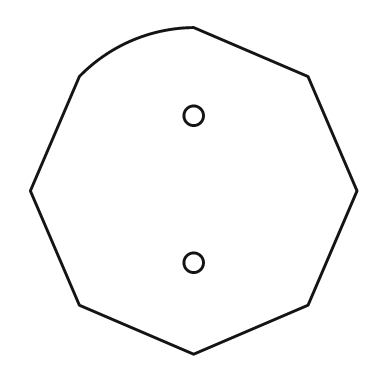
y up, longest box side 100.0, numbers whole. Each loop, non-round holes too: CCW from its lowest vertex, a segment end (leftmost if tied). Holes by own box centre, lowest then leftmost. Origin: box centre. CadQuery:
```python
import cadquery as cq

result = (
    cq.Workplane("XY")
    .moveTo(0.0, -50.0)
    .lineTo(35.0, -35.0)
    .lineTo(50.0, 0.0)
    .lineTo(35.0, 35.0)
    .lineTo(0.0, 50.0)
    .threePointArc((-19.0, 46.0), (-35.0, 35.0))
    .lineTo(-50.0, 0.0)
    .lineTo(-35.0, -35.0)
    .close()
    .moveTo(0.0, -22.0)
    .circle(3.0)
    .moveTo(0.0, 23.0)
    .circle(3.0)
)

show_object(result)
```